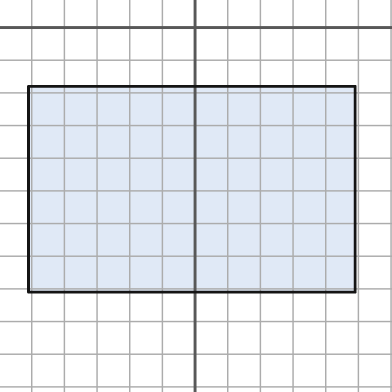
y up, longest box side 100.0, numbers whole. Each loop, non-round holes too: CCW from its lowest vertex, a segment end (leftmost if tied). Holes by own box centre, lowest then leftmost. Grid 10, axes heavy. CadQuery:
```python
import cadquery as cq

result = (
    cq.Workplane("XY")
    .moveTo(-51.0, -81.0)
    .lineTo(49.0, -81.0)
    .lineTo(49.0, -18.0)
    .lineTo(-51.0, -18.0)
    .close()
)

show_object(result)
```